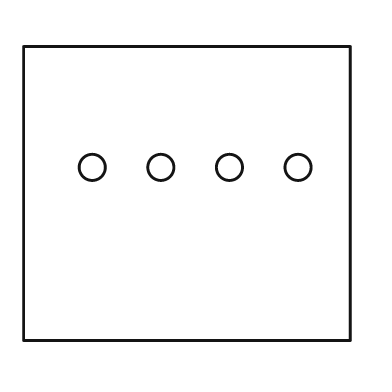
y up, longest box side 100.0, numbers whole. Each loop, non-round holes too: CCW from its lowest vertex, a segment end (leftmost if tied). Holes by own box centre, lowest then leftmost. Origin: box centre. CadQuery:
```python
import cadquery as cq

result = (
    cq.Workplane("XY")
    .moveTo(-50.0, -45.0)
    .lineTo(50.0, -45.0)
    .lineTo(50.0, 45.0)
    .lineTo(-50.0, 45.0)
    .close()
    .moveTo(-29.0, 8.0)
    .circle(4.0)
    .moveTo(-8.0, 8.0)
    .circle(4.0)
    .moveTo(13.0, 8.0)
    .circle(4.0)
    .moveTo(34.0, 8.0)
    .circle(4.0)
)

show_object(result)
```